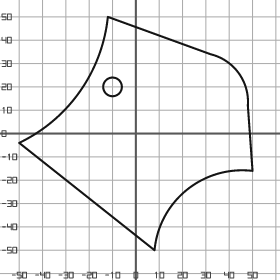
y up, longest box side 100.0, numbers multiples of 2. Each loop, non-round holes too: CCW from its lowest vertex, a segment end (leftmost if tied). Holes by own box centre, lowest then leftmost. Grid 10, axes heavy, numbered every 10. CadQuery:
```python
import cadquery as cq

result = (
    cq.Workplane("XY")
    .moveTo(8.0, -50.0)
    .threePointArc((22.0, -24.0), (50.0, -16.0))
    .lineTo(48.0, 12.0)
    .threePointArc((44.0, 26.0), (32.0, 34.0))
    .lineTo(-12.0, 50.0)
    .threePointArc((-24.0, 18.0), (-50.0, -4.0))
    .close()
    .moveTo(-10.0, 20.0)
    .circle(4.0)
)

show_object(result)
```